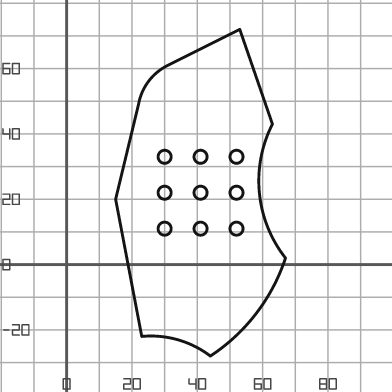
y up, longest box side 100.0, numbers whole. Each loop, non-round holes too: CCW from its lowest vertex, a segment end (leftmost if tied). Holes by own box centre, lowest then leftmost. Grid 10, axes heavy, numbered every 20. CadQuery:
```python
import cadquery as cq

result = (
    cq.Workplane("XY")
    .moveTo(44.0, -28.0)
    .threePointArc((58.0, -15.0), (67.0, 2.0))
    .threePointArc((59.0, 22.0), (63.0, 43.0))
    .lineTo(53.0, 72.0)
    .lineTo(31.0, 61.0)
    .threePointArc((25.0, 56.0), (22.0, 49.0))
    .lineTo(15.0, 20.0)
    .lineTo(23.0, -22.0)
    .threePointArc((34.0, -23.0), (44.0, -28.0))
    .close()
    .moveTo(30.0, 11.0)
    .circle(2.0)
    .moveTo(41.0, 11.0)
    .circle(2.0)
    .moveTo(52.0, 11.0)
    .circle(2.0)
    .moveTo(30.0, 22.0)
    .circle(2.0)
    .moveTo(41.0, 22.0)
    .circle(2.0)
    .moveTo(52.0, 22.0)
    .circle(2.0)
    .moveTo(30.0, 33.0)
    .circle(2.0)
    .moveTo(41.0, 33.0)
    .circle(2.0)
    .moveTo(52.0, 33.0)
    .circle(2.0)
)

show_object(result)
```